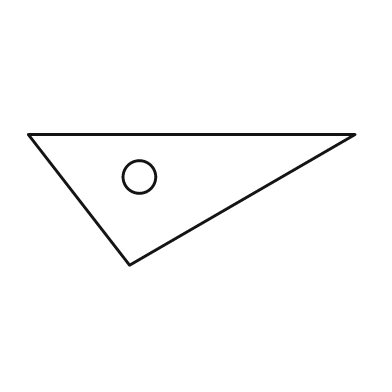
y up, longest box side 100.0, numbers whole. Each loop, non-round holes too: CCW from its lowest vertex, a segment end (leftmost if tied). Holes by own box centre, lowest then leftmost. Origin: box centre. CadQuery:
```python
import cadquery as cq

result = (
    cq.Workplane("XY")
    .moveTo(-19.0, -20.0)
    .lineTo(50.0, 20.0)
    .lineTo(-50.0, 20.0)
    .close()
    .moveTo(-16.0, 7.0)
    .circle(5.0)
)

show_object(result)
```